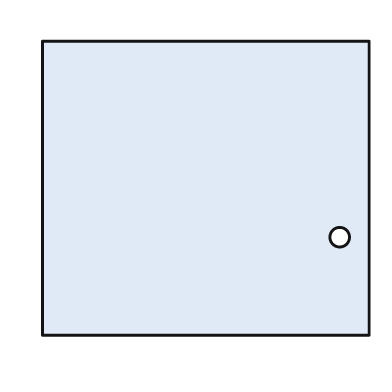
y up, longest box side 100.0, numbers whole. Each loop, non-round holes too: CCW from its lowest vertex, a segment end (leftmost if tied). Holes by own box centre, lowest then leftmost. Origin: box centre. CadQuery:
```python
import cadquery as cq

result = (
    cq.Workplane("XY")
    .moveTo(-50.0, -45.0)
    .lineTo(50.0, -45.0)
    .lineTo(50.0, 45.0)
    .lineTo(-50.0, 45.0)
    .close()
    .moveTo(41.0, -15.0)
    .circle(3.0)
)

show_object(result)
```